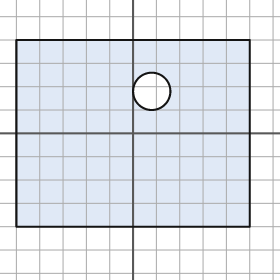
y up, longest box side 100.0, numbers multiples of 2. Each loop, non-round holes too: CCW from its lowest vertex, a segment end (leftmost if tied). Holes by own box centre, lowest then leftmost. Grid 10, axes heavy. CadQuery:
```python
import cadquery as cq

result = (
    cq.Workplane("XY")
    .moveTo(-50.0, -40.0)
    .lineTo(50.0, -40.0)
    .lineTo(50.0, 40.0)
    .lineTo(-50.0, 40.0)
    .close()
    .moveTo(8.0, 18.0)
    .circle(8.0)
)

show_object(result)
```